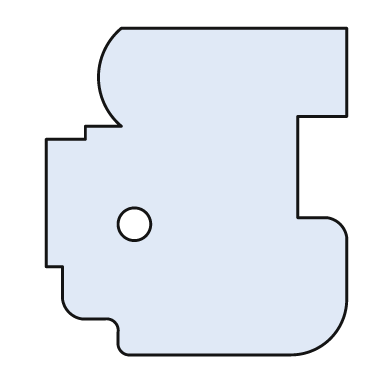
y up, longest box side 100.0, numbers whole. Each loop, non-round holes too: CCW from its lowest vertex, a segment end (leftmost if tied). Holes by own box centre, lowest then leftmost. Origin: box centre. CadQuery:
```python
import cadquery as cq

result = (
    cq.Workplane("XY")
    .moveTo(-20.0, -50.0)
    .lineTo(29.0, -50.0)
    .threePointArc((41.0, -45.0), (46.0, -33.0))
    .lineTo(46.0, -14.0)
    .threePointArc((44.0, -10.0), (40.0, -8.0))
    .lineTo(31.0, -8.0)
    .lineTo(31.0, 23.0)
    .lineTo(46.0, 23.0)
    .lineTo(46.0, 50.0)
    .lineTo(-23.0, 50.0)
    .threePointArc((-30.0, 35.0), (-23.0, 20.0))
    .lineTo(-34.0, 20.0)
    .lineTo(-34.0, 16.0)
    .lineTo(-46.0, 16.0)
    .lineTo(-46.0, -23.0)
    .lineTo(-41.0, -23.0)
    .lineTo(-41.0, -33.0)
    .threePointArc((-39.0, -37.0), (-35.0, -39.0))
    .lineTo(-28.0, -39.0)
    .threePointArc((-25.0, -40.0), (-24.0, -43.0))
    .lineTo(-24.0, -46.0)
    .threePointArc((-23.0, -49.0), (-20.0, -50.0))
    .close()
    .moveTo(-19.0, -10.0)
    .circle(5.0)
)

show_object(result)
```